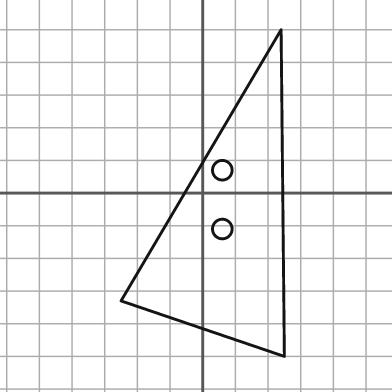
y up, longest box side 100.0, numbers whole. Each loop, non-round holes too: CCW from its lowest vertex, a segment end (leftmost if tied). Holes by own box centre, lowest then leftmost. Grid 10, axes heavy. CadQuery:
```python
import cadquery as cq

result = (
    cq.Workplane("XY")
    .moveTo(25.0, -50.0)
    .lineTo(24.0, 50.0)
    .lineTo(-25.0, -33.0)
    .close()
    .moveTo(6.0, -11.0)
    .circle(3.0)
    .moveTo(6.0, 7.0)
    .circle(3.0)
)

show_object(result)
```